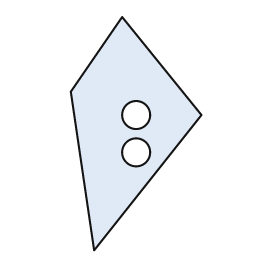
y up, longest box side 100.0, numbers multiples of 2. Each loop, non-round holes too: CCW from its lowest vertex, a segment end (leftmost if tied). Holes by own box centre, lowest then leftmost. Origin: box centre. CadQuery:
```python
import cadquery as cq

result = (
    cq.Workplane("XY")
    .moveTo(-18.0, -50.0)
    .lineTo(28.0, 8.0)
    .lineTo(-6.0, 50.0)
    .lineTo(-28.0, 18.0)
    .close()
    .moveTo(0.0, -8.0)
    .circle(6.0)
    .moveTo(0.0, 8.0)
    .circle(6.0)
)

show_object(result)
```